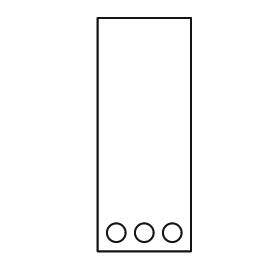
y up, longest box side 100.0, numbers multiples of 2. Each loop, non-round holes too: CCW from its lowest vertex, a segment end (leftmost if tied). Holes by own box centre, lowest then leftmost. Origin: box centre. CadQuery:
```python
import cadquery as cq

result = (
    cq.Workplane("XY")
    .moveTo(-20.0, -50.0)
    .lineTo(20.0, -50.0)
    .lineTo(20.0, 50.0)
    .lineTo(-20.0, 50.0)
    .close()
    .moveTo(-12.0, -42.0)
    .circle(4.0)
    .moveTo(0.0, -42.0)
    .circle(4.0)
    .moveTo(12.0, -42.0)
    .circle(4.0)
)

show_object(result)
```